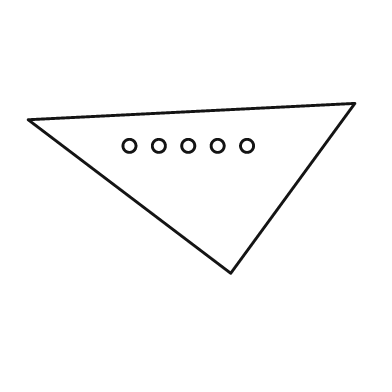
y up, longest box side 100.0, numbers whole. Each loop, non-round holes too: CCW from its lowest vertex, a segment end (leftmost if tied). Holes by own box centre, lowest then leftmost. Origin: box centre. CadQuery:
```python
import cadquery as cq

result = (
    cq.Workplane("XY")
    .moveTo(12.0, -26.0)
    .lineTo(50.0, 26.0)
    .lineTo(-50.0, 21.0)
    .close()
    .moveTo(-19.0, 13.0)
    .circle(2.0)
    .moveTo(-10.0, 13.0)
    .circle(2.0)
    .moveTo(-1.0, 13.0)
    .circle(2.0)
    .moveTo(8.0, 13.0)
    .circle(2.0)
    .moveTo(17.0, 13.0)
    .circle(2.0)
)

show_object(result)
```